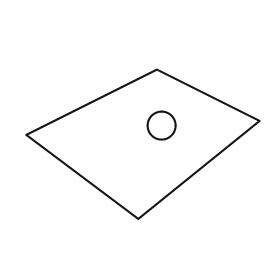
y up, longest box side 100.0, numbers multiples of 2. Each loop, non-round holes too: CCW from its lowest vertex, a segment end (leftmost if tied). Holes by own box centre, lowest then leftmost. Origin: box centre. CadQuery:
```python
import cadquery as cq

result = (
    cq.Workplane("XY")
    .moveTo(-2.0, -32.0)
    .lineTo(50.0, 10.0)
    .lineTo(6.0, 32.0)
    .lineTo(-50.0, 4.0)
    .close()
    .moveTo(8.0, 8.0)
    .circle(6.0)
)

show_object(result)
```